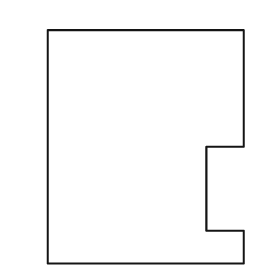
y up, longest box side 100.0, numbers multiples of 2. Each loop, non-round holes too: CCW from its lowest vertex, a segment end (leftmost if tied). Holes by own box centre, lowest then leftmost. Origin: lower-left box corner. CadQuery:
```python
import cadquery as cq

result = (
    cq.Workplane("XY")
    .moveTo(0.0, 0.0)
    .lineTo(84.0, 0.0)
    .lineTo(84.0, 14.0)
    .lineTo(68.0, 14.0)
    .lineTo(68.0, 50.0)
    .lineTo(84.0, 50.0)
    .lineTo(84.0, 100.0)
    .lineTo(0.0, 100.0)
    .close()
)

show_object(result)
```